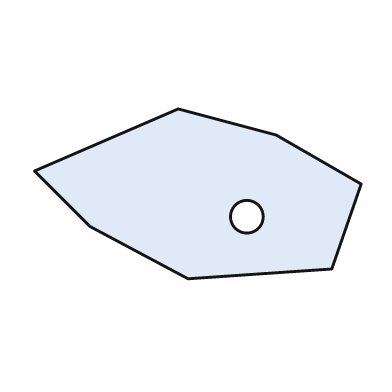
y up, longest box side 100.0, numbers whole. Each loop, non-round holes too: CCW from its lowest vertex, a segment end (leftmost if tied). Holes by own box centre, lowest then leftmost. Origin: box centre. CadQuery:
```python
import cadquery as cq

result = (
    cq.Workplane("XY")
    .moveTo(-3.0, -26.0)
    .lineTo(41.0, -23.0)
    .lineTo(50.0, 3.0)
    .lineTo(24.0, 18.0)
    .lineTo(-6.0, 26.0)
    .lineTo(-50.0, 7.0)
    .lineTo(-33.0, -10.0)
    .close()
    .moveTo(15.0, -7.0)
    .circle(5.0)
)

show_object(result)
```